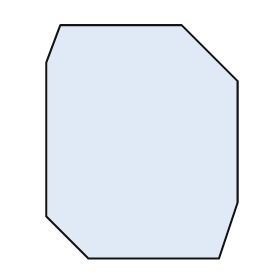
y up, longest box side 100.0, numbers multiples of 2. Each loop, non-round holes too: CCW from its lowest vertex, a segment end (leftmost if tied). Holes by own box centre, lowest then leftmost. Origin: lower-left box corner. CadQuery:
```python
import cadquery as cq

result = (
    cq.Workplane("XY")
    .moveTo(18.0, 0.0)
    .lineTo(74.0, 0.0)
    .lineTo(82.0, 24.0)
    .lineTo(82.0, 76.0)
    .lineTo(58.0, 100.0)
    .lineTo(6.0, 100.0)
    .lineTo(0.0, 84.0)
    .lineTo(0.0, 18.0)
    .close()
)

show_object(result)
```